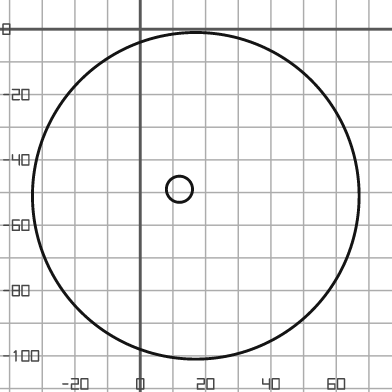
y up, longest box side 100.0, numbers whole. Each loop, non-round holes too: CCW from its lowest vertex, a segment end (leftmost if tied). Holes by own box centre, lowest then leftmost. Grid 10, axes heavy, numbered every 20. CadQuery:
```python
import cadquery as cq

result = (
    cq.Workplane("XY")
    .moveTo(17.0, -51.0)
    .circle(50.0)
    .moveTo(12.0, -49.0)
    .circle(4.0)
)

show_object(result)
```